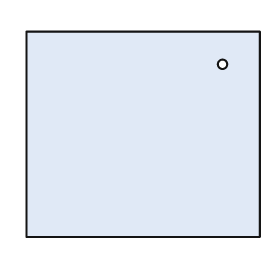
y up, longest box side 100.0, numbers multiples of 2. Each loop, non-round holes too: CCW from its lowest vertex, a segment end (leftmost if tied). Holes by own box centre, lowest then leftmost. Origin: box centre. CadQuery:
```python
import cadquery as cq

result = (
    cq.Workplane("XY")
    .moveTo(-50.0, -44.0)
    .lineTo(50.0, -44.0)
    .lineTo(50.0, 44.0)
    .lineTo(-50.0, 44.0)
    .close()
    .moveTo(34.0, 30.0)
    .circle(2.0)
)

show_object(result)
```